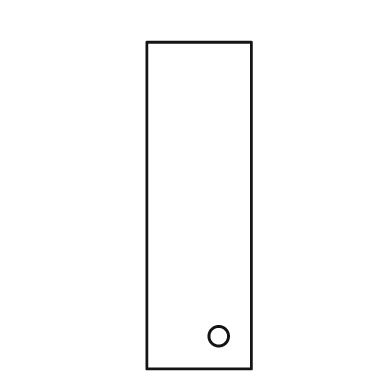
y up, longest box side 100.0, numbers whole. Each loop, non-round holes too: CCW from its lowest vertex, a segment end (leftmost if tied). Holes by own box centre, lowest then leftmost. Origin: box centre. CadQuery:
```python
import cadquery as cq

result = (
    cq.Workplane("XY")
    .moveTo(-16.0, -50.0)
    .lineTo(16.0, -50.0)
    .lineTo(16.0, 50.0)
    .lineTo(-16.0, 50.0)
    .close()
    .moveTo(6.0, -40.0)
    .circle(3.0)
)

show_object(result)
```